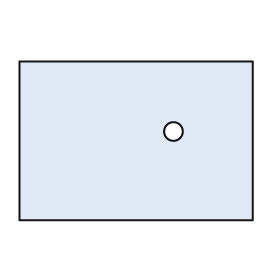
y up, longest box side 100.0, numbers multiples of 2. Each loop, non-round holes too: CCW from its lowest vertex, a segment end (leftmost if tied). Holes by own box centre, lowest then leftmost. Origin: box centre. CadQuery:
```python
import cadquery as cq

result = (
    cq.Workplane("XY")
    .moveTo(-50.0, -34.0)
    .lineTo(50.0, -34.0)
    .lineTo(50.0, 34.0)
    .lineTo(-50.0, 34.0)
    .close()
    .moveTo(16.0, 4.0)
    .circle(4.0)
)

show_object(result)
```